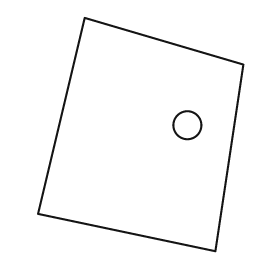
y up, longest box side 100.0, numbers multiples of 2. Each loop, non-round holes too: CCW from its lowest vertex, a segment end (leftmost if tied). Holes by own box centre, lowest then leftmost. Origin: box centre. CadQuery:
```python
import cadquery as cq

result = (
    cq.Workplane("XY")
    .moveTo(32.0, -50.0)
    .lineTo(44.0, 30.0)
    .lineTo(-24.0, 50.0)
    .lineTo(-44.0, -34.0)
    .close()
    .moveTo(20.0, 4.0)
    .circle(6.0)
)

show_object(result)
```